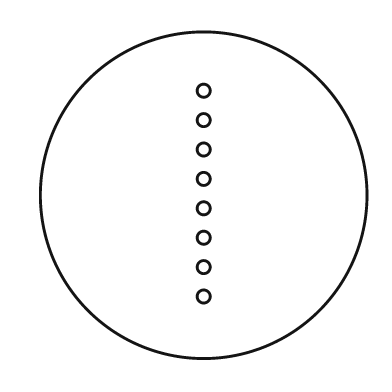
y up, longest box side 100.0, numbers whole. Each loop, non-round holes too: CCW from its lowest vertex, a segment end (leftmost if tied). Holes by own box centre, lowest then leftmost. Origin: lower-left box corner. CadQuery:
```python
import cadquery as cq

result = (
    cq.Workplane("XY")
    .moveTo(50.0, 50.0)
    .circle(50.0)
    .moveTo(50.0, 19.0)
    .circle(2.0)
    .moveTo(50.0, 28.0)
    .circle(2.0)
    .moveTo(50.0, 37.0)
    .circle(2.0)
    .moveTo(50.0, 46.0)
    .circle(2.0)
    .moveTo(50.0, 55.0)
    .circle(2.0)
    .moveTo(50.0, 64.0)
    .circle(2.0)
    .moveTo(50.0, 73.0)
    .circle(2.0)
    .moveTo(50.0, 82.0)
    .circle(2.0)
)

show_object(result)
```